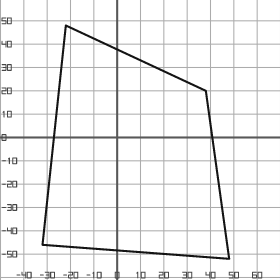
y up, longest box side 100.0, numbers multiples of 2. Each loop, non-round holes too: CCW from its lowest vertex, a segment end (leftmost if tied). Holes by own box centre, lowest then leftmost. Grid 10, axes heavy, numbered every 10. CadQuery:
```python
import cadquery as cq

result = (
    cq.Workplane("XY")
    .moveTo(48.0, -52.0)
    .lineTo(38.0, 20.0)
    .lineTo(-22.0, 48.0)
    .lineTo(-32.0, -46.0)
    .close()
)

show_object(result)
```